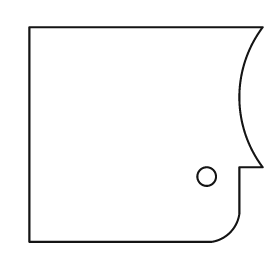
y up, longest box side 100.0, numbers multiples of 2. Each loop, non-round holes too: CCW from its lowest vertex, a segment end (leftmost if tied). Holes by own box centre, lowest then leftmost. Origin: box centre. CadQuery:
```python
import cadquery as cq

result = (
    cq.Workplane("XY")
    .moveTo(-50.0, -46.0)
    .lineTo(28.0, -46.0)
    .threePointArc((36.0, -42.0), (40.0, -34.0))
    .lineTo(40.0, -14.0)
    .lineTo(50.0, -14.0)
    .threePointArc((40.0, 16.0), (50.0, 46.0))
    .lineTo(-50.0, 46.0)
    .close()
    .moveTo(26.0, -18.0)
    .circle(4.0)
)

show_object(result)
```